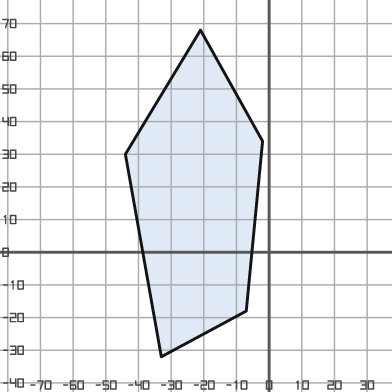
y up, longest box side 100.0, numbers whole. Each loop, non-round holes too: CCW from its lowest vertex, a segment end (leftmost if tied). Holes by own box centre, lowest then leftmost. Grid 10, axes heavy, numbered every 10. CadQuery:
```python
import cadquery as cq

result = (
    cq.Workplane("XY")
    .moveTo(-33.0, -32.0)
    .lineTo(-7.0, -18.0)
    .lineTo(-2.0, 34.0)
    .lineTo(-21.0, 68.0)
    .lineTo(-44.0, 30.0)
    .close()
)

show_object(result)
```